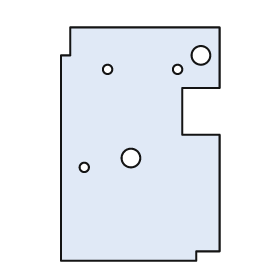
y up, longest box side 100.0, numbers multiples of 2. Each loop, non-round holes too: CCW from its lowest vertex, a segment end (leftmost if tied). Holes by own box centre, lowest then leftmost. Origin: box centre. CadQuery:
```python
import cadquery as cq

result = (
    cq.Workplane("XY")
    .moveTo(-34.0, -50.0)
    .lineTo(24.0, -50.0)
    .lineTo(24.0, -46.0)
    .lineTo(34.0, -46.0)
    .lineTo(34.0, 4.0)
    .lineTo(18.0, 4.0)
    .lineTo(18.0, 24.0)
    .lineTo(34.0, 24.0)
    .lineTo(34.0, 50.0)
    .lineTo(-30.0, 50.0)
    .lineTo(-30.0, 38.0)
    .lineTo(-34.0, 38.0)
    .close()
    .moveTo(-24.0, -10.0)
    .circle(2.0)
    .moveTo(-4.0, -6.0)
    .circle(4.0)
    .moveTo(-14.0, 32.0)
    .circle(2.0)
    .moveTo(16.0, 32.0)
    .circle(2.0)
    .moveTo(26.0, 38.0)
    .circle(4.0)
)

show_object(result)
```